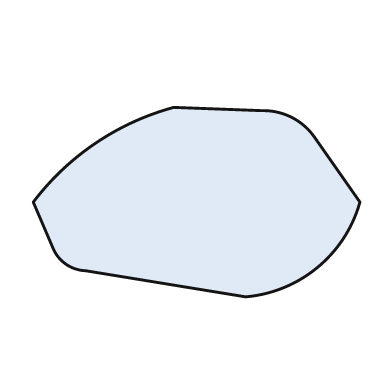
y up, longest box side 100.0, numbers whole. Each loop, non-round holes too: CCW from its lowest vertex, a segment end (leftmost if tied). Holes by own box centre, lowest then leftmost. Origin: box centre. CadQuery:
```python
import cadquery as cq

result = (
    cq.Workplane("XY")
    .moveTo(15.0, -29.0)
    .threePointArc((37.0, -20.0), (50.0, 0.0))
    .lineTo(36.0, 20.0)
    .threePointArc((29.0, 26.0), (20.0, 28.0))
    .lineTo(-7.0, 29.0)
    .threePointArc((-31.0, 18.0), (-50.0, 0.0))
    .lineTo(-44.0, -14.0)
    .threePointArc((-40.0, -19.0), (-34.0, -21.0))
    .close()
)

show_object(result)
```